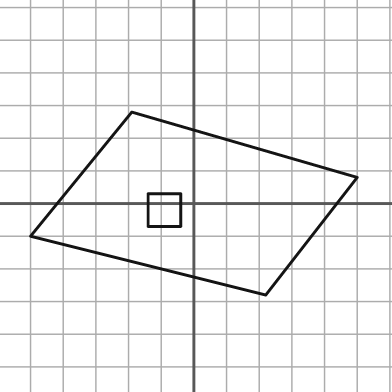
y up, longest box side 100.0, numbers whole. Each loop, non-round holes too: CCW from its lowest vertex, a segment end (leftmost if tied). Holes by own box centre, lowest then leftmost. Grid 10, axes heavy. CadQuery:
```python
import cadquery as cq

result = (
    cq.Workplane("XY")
    .moveTo(22.0, -28.0)
    .lineTo(50.0, 8.0)
    .lineTo(-19.0, 28.0)
    .lineTo(-50.0, -10.0)
    .close()
    .moveTo(-14.0, -7.0)
    .lineTo(-4.0, -7.0)
    .lineTo(-4.0, 3.0)
    .lineTo(-14.0, 3.0)
    .close()
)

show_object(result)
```